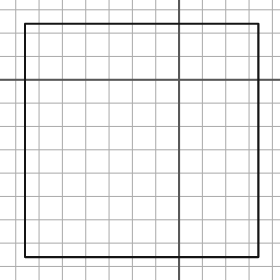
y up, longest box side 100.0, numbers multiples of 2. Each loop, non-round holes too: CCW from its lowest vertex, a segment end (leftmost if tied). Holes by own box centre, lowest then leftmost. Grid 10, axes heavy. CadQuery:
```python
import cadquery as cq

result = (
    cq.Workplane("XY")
    .moveTo(-66.0, -76.0)
    .lineTo(34.0, -76.0)
    .lineTo(34.0, 24.0)
    .lineTo(-66.0, 24.0)
    .close()
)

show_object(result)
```